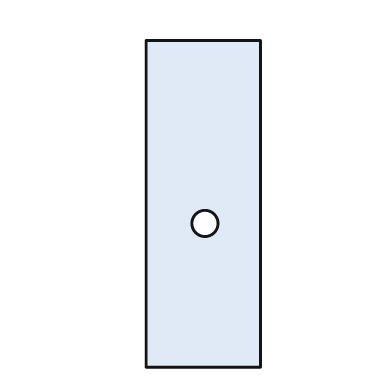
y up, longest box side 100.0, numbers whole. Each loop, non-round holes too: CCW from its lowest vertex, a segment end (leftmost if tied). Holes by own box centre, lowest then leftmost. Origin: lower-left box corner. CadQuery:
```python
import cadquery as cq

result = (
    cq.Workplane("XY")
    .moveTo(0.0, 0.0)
    .lineTo(35.0, 0.0)
    .lineTo(35.0, 100.0)
    .lineTo(0.0, 100.0)
    .close()
    .moveTo(18.0, 44.0)
    .circle(4.0)
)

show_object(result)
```